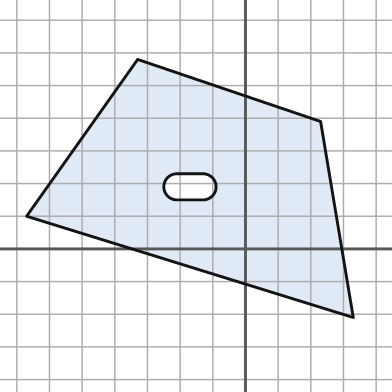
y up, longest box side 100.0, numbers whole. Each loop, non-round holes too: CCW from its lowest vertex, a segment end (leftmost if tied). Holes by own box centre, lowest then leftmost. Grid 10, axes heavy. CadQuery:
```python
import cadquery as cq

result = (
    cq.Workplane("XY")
    .moveTo(33.0, -21.0)
    .lineTo(23.0, 39.0)
    .lineTo(-33.0, 58.0)
    .lineTo(-67.0, 10.0)
    .close()
    .moveTo(-21.0, 15.0)
    .lineTo(-13.0, 15.0)
    .threePointArc((-9.0, 19.0), (-13.0, 23.0))
    .lineTo(-21.0, 23.0)
    .threePointArc((-25.0, 19.0), (-21.0, 15.0))
    .close()
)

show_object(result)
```